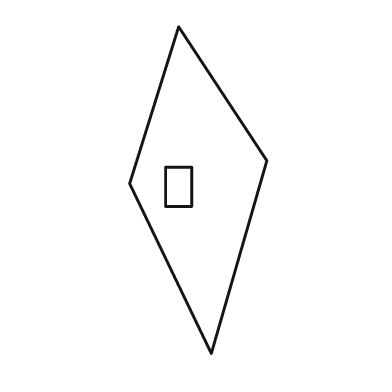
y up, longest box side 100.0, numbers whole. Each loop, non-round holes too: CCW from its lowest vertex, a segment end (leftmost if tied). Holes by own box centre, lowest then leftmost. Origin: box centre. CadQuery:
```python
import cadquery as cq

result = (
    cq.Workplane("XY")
    .moveTo(4.0, -50.0)
    .lineTo(21.0, 9.0)
    .lineTo(-6.0, 50.0)
    .lineTo(-21.0, 2.0)
    .close()
    .moveTo(-10.0, -5.0)
    .lineTo(-2.0, -5.0)
    .lineTo(-2.0, 7.0)
    .lineTo(-10.0, 7.0)
    .close()
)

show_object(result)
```